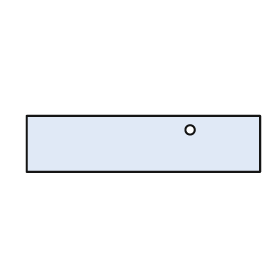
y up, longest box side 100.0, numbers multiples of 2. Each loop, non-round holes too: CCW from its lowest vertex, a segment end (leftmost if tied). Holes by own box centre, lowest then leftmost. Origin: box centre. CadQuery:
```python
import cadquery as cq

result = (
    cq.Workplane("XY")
    .moveTo(-50.0, -12.0)
    .lineTo(50.0, -12.0)
    .lineTo(50.0, 12.0)
    .lineTo(-50.0, 12.0)
    .close()
    .moveTo(20.0, 6.0)
    .circle(2.0)
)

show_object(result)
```